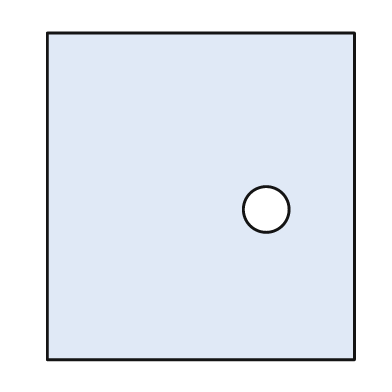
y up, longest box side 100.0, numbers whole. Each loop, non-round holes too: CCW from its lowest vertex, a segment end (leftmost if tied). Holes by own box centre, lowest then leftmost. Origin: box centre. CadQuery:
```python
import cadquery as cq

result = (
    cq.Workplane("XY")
    .moveTo(-47.0, -50.0)
    .lineTo(47.0, -50.0)
    .lineTo(47.0, 50.0)
    .lineTo(-47.0, 50.0)
    .close()
    .moveTo(20.0, -4.0)
    .circle(7.0)
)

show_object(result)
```